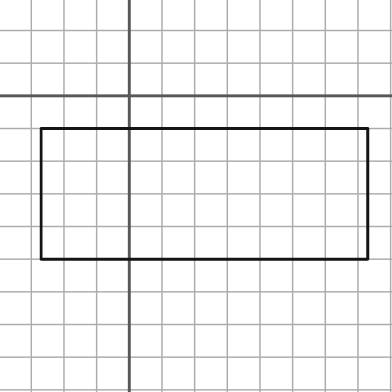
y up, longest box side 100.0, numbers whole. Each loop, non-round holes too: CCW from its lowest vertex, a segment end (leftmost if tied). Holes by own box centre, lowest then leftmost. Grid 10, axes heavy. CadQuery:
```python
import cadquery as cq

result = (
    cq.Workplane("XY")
    .moveTo(-27.0, -50.0)
    .lineTo(73.0, -50.0)
    .lineTo(73.0, -10.0)
    .lineTo(-27.0, -10.0)
    .close()
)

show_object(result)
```